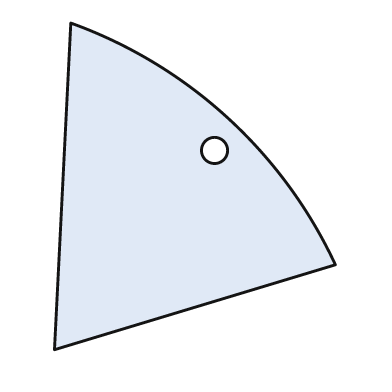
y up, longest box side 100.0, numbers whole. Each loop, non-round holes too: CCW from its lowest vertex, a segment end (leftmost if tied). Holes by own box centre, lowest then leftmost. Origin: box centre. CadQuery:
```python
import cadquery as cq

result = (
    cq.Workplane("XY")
    .moveTo(-43.0, -50.0)
    .lineTo(43.0, -24.0)
    .threePointArc((10.0, 21.0), (-38.0, 50.0))
    .close()
    .moveTo(6.0, 11.0)
    .circle(4.0)
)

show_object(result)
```